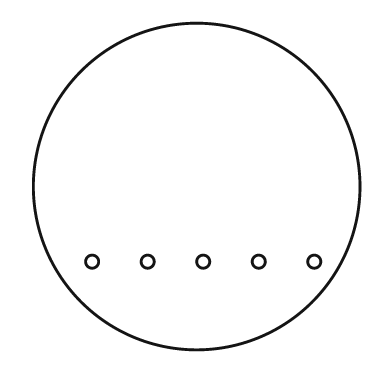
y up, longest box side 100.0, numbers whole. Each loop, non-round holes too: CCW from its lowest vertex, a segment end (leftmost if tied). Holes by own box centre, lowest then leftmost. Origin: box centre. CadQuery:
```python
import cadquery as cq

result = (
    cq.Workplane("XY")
    .moveTo(0.0, 0.0)
    .circle(50.0)
    .moveTo(-32.0, -23.0)
    .circle(2.0)
    .moveTo(-15.0, -23.0)
    .circle(2.0)
    .moveTo(2.0, -23.0)
    .circle(2.0)
    .moveTo(19.0, -23.0)
    .circle(2.0)
    .moveTo(36.0, -23.0)
    .circle(2.0)
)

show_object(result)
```